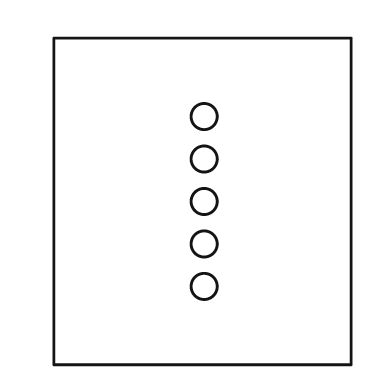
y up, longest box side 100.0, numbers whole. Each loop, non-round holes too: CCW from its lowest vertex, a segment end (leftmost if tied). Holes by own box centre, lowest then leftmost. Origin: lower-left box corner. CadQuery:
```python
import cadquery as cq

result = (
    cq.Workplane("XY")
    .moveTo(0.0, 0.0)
    .lineTo(91.0, 0.0)
    .lineTo(91.0, 100.0)
    .lineTo(0.0, 100.0)
    .close()
    .moveTo(46.0, 24.0)
    .circle(4.0)
    .moveTo(46.0, 37.0)
    .circle(4.0)
    .moveTo(46.0, 50.0)
    .circle(4.0)
    .moveTo(46.0, 63.0)
    .circle(4.0)
    .moveTo(46.0, 76.0)
    .circle(4.0)
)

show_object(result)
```